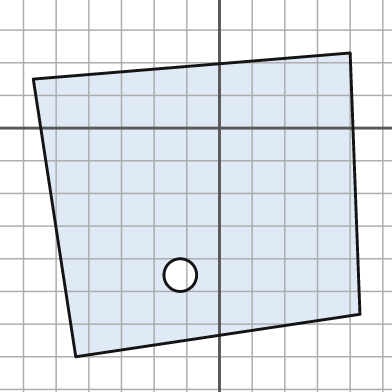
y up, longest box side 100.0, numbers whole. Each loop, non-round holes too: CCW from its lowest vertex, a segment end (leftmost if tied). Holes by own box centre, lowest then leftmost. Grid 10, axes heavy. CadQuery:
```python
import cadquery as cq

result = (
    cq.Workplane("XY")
    .moveTo(-44.0, -70.0)
    .lineTo(43.0, -57.0)
    .lineTo(40.0, 23.0)
    .lineTo(-57.0, 15.0)
    .close()
    .moveTo(-12.0, -45.0)
    .circle(5.0)
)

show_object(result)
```